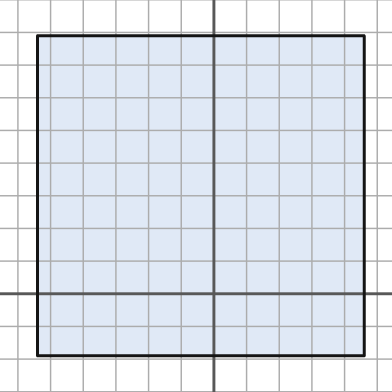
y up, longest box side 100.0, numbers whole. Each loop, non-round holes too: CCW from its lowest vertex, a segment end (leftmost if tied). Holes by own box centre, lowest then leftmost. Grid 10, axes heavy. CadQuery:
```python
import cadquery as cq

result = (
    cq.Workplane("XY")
    .moveTo(-54.0, -19.0)
    .lineTo(46.0, -19.0)
    .lineTo(46.0, 79.0)
    .lineTo(-54.0, 79.0)
    .close()
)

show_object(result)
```